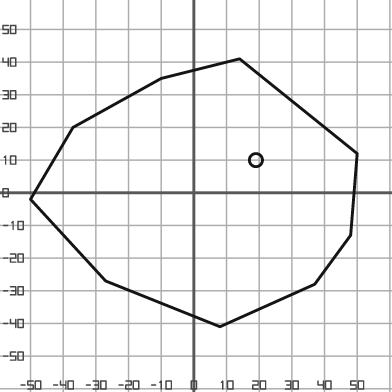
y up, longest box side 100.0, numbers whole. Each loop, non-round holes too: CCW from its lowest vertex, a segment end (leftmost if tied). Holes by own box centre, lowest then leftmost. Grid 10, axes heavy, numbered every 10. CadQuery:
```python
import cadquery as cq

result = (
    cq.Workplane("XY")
    .moveTo(8.0, -41.0)
    .lineTo(37.0, -28.0)
    .lineTo(48.0, -13.0)
    .lineTo(50.0, 12.0)
    .lineTo(14.0, 41.0)
    .lineTo(-10.0, 35.0)
    .lineTo(-37.0, 20.0)
    .lineTo(-50.0, -2.0)
    .lineTo(-27.0, -27.0)
    .close()
    .moveTo(19.0, 10.0)
    .circle(2.0)
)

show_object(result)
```